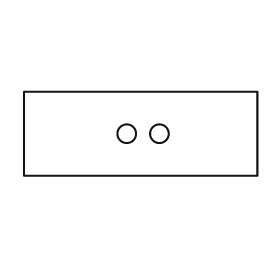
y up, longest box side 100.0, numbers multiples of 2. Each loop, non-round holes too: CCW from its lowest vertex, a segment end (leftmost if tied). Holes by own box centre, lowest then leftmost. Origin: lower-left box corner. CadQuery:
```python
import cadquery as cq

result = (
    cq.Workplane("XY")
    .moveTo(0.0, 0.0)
    .lineTo(100.0, 0.0)
    .lineTo(100.0, 36.0)
    .lineTo(0.0, 36.0)
    .close()
    .moveTo(44.0, 18.0)
    .circle(4.0)
    .moveTo(58.0, 18.0)
    .circle(4.0)
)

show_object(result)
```